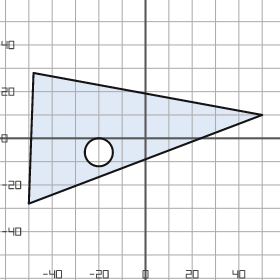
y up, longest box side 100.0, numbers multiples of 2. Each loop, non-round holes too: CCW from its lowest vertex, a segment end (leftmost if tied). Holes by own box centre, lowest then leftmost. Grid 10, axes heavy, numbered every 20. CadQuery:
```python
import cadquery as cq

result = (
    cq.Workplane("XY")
    .moveTo(-50.0, -28.0)
    .lineTo(50.0, 10.0)
    .lineTo(-48.0, 28.0)
    .close()
    .moveTo(-20.0, -6.0)
    .circle(6.0)
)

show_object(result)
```